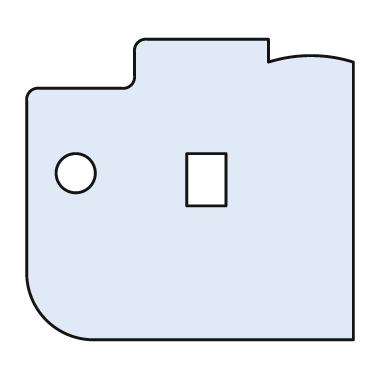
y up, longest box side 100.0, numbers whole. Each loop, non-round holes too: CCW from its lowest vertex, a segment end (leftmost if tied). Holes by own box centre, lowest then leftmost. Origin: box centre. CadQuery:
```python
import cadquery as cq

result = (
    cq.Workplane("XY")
    .moveTo(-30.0, -46.0)
    .lineTo(50.0, -46.0)
    .lineTo(50.0, 39.0)
    .threePointArc((37.0, 41.0), (24.0, 39.0))
    .lineTo(24.0, 46.0)
    .lineTo(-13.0, 46.0)
    .threePointArc((-16.0, 45.0), (-17.0, 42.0))
    .lineTo(-17.0, 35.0)
    .threePointArc((-18.0, 32.0), (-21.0, 31.0))
    .lineTo(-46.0, 31.0)
    .threePointArc((-49.0, 30.0), (-50.0, 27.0))
    .lineTo(-50.0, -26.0)
    .threePointArc((-44.0, -40.0), (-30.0, -46.0))
    .close()
    .moveTo(-1.0, -5.0)
    .lineTo(11.0, -5.0)
    .lineTo(11.0, 11.0)
    .lineTo(-1.0, 11.0)
    .close()
    .moveTo(-35.0, 5.0)
    .circle(6.0)
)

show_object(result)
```